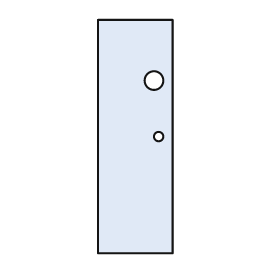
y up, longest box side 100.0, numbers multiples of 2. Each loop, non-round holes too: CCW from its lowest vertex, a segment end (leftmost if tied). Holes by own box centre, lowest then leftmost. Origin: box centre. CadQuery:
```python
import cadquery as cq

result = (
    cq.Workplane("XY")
    .moveTo(-16.0, -50.0)
    .lineTo(16.0, -50.0)
    .lineTo(16.0, 50.0)
    .lineTo(-16.0, 50.0)
    .close()
    .moveTo(10.0, 0.0)
    .circle(2.0)
    .moveTo(8.0, 24.0)
    .circle(4.0)
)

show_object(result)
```